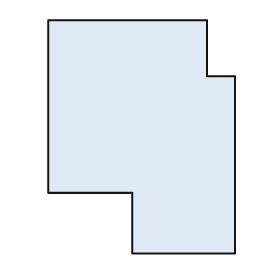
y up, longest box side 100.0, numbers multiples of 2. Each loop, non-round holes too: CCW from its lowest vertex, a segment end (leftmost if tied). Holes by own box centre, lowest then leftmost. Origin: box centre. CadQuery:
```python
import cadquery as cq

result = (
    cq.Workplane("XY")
    .moveTo(-4.0, -50.0)
    .lineTo(40.0, -50.0)
    .lineTo(40.0, 26.0)
    .lineTo(28.0, 26.0)
    .lineTo(28.0, 50.0)
    .lineTo(-40.0, 50.0)
    .lineTo(-40.0, -24.0)
    .lineTo(-4.0, -24.0)
    .close()
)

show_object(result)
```